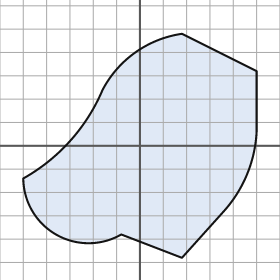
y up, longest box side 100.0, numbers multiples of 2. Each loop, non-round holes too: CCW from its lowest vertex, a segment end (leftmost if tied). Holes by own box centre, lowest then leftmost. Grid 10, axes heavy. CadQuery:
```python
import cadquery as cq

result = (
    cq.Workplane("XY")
    .moveTo(18.0, -48.0)
    .lineTo(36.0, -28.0)
    .threePointArc((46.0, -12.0), (50.0, 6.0))
    .lineTo(50.0, 32.0)
    .lineTo(18.0, 48.0)
    .threePointArc((-2.0, 40.0), (-16.0, 24.0))
    .threePointArc((-30.0, 2.0), (-50.0, -14.0))
    .threePointArc((-36.0, -38.0), (-8.0, -38.0))
    .close()
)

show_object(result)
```